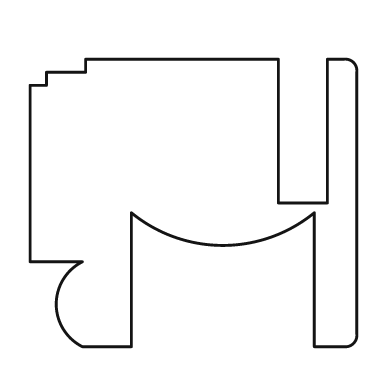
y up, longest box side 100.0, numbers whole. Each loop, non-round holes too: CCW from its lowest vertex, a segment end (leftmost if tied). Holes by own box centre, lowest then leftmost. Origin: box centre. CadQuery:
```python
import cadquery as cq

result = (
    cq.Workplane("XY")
    .moveTo(-34.0, -44.0)
    .lineTo(-19.0, -44.0)
    .lineTo(-19.0, -3.0)
    .threePointArc((9.0, -13.0), (37.0, -3.0))
    .lineTo(37.0, -44.0)
    .lineTo(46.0, -44.0)
    .threePointArc((49.0, -43.0), (50.0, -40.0))
    .lineTo(50.0, 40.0)
    .threePointArc((49.0, 43.0), (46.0, 44.0))
    .lineTo(41.0, 44.0)
    .lineTo(41.0, 0.0)
    .lineTo(26.0, 0.0)
    .lineTo(26.0, 44.0)
    .lineTo(-33.0, 44.0)
    .lineTo(-33.0, 40.0)
    .lineTo(-45.0, 40.0)
    .lineTo(-45.0, 36.0)
    .lineTo(-50.0, 36.0)
    .lineTo(-50.0, -18.0)
    .lineTo(-34.0, -18.0)
    .threePointArc((-42.0, -31.0), (-34.0, -44.0))
    .close()
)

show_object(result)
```